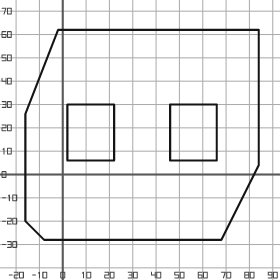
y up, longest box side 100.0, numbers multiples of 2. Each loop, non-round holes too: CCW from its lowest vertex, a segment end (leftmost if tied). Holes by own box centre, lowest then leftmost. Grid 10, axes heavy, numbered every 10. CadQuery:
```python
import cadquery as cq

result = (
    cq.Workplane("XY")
    .moveTo(-8.0, -28.0)
    .lineTo(68.0, -28.0)
    .lineTo(84.0, 4.0)
    .lineTo(84.0, 62.0)
    .lineTo(-2.0, 62.0)
    .lineTo(-16.0, 26.0)
    .lineTo(-16.0, -20.0)
    .close()
    .moveTo(2.0, 6.0)
    .lineTo(22.0, 6.0)
    .lineTo(22.0, 30.0)
    .lineTo(2.0, 30.0)
    .close()
    .moveTo(46.0, 6.0)
    .lineTo(66.0, 6.0)
    .lineTo(66.0, 30.0)
    .lineTo(46.0, 30.0)
    .close()
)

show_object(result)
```